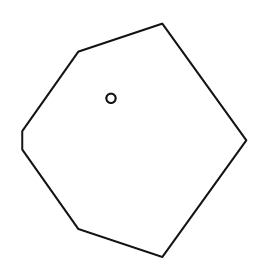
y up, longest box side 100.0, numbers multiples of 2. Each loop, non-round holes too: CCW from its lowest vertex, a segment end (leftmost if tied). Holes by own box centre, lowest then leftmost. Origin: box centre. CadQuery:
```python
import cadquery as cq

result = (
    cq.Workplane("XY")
    .moveTo(12.0, -50.0)
    .lineTo(48.0, 0.0)
    .lineTo(12.0, 50.0)
    .lineTo(-24.0, 38.0)
    .lineTo(-48.0, 4.0)
    .lineTo(-48.0, -4.0)
    .lineTo(-24.0, -38.0)
    .close()
    .moveTo(-10.0, 18.0)
    .circle(2.0)
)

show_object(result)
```